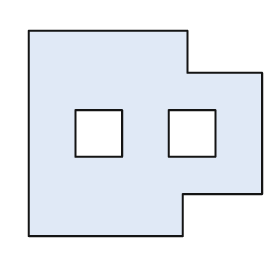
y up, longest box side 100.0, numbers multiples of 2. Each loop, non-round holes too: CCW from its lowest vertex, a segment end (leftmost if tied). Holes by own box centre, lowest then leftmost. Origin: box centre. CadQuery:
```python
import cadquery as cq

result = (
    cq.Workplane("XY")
    .moveTo(-50.0, -44.0)
    .lineTo(16.0, -44.0)
    .lineTo(16.0, -26.0)
    .lineTo(50.0, -26.0)
    .lineTo(50.0, 26.0)
    .lineTo(18.0, 26.0)
    .lineTo(18.0, 44.0)
    .lineTo(-50.0, 44.0)
    .close()
    .moveTo(-30.0, -10.0)
    .lineTo(-10.0, -10.0)
    .lineTo(-10.0, 10.0)
    .lineTo(-30.0, 10.0)
    .close()
    .moveTo(10.0, -10.0)
    .lineTo(30.0, -10.0)
    .lineTo(30.0, 10.0)
    .lineTo(10.0, 10.0)
    .close()
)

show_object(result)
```